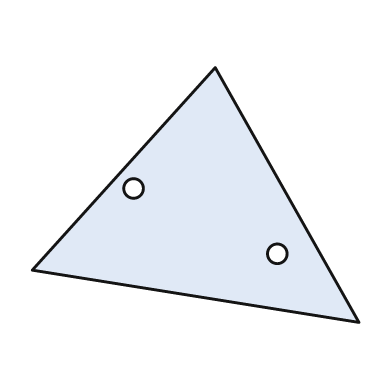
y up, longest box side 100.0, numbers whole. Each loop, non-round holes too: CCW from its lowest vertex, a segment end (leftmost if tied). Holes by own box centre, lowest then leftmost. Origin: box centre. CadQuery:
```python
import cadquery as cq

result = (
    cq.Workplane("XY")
    .moveTo(50.0, -39.0)
    .lineTo(6.0, 39.0)
    .lineTo(-50.0, -23.0)
    .close()
    .moveTo(25.0, -18.0)
    .circle(3.0)
    .moveTo(-19.0, 2.0)
    .circle(3.0)
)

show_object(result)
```